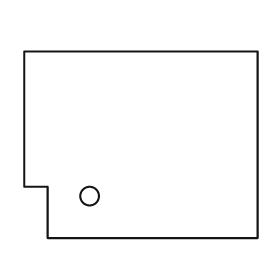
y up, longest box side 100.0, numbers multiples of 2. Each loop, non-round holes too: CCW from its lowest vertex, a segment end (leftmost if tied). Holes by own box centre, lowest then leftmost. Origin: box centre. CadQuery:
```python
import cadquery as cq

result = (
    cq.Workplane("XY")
    .moveTo(-40.0, -40.0)
    .lineTo(50.0, -40.0)
    .lineTo(50.0, 40.0)
    .lineTo(-50.0, 40.0)
    .lineTo(-50.0, -18.0)
    .lineTo(-40.0, -18.0)
    .close()
    .moveTo(-22.0, -22.0)
    .circle(4.0)
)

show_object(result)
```